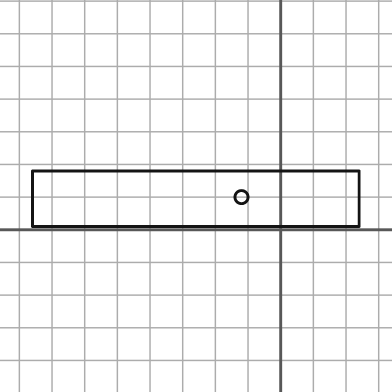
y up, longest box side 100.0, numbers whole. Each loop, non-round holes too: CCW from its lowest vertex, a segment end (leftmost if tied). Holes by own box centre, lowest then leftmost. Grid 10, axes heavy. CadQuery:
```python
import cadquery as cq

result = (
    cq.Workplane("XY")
    .moveTo(-76.0, 1.0)
    .lineTo(24.0, 1.0)
    .lineTo(24.0, 18.0)
    .lineTo(-76.0, 18.0)
    .close()
    .moveTo(-12.0, 10.0)
    .circle(2.0)
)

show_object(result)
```